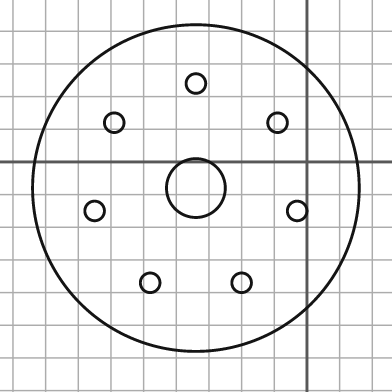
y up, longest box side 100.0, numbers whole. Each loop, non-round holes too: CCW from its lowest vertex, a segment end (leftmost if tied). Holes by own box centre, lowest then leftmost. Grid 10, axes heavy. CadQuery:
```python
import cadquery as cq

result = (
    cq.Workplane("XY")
    .moveTo(-34.0, -8.0)
    .circle(50.0)
    .moveTo(-48.0, -37.0)
    .circle(3.0)
    .moveTo(-20.0, -37.0)
    .circle(3.0)
    .moveTo(-65.0, -15.0)
    .circle(3.0)
    .moveTo(-3.0, -15.0)
    .circle(3.0)
    .moveTo(-34.0, -8.0)
    .circle(9.0)
    .moveTo(-59.0, 12.0)
    .circle(3.0)
    .moveTo(-9.0, 12.0)
    .circle(3.0)
    .moveTo(-34.0, 24.0)
    .circle(3.0)
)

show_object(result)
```